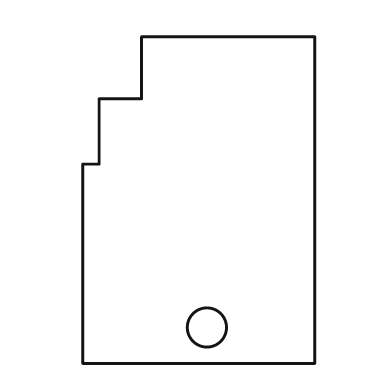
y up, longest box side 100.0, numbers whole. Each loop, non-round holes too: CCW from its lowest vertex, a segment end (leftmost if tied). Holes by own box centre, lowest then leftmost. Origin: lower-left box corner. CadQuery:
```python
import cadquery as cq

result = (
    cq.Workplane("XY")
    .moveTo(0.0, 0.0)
    .lineTo(71.0, 0.0)
    .lineTo(71.0, 100.0)
    .lineTo(18.0, 100.0)
    .lineTo(18.0, 81.0)
    .lineTo(5.0, 81.0)
    .lineTo(5.0, 61.0)
    .lineTo(0.0, 61.0)
    .close()
    .moveTo(38.0, 11.0)
    .circle(6.0)
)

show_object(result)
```